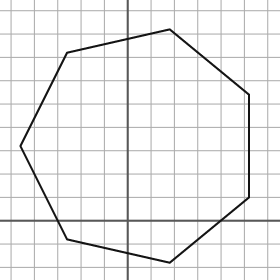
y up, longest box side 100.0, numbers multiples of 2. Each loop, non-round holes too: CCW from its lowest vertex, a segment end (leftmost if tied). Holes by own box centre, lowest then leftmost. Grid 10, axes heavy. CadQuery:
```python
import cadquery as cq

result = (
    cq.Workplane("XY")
    .moveTo(18.0, -18.0)
    .lineTo(52.0, 10.0)
    .lineTo(52.0, 54.0)
    .lineTo(18.0, 82.0)
    .lineTo(-26.0, 72.0)
    .lineTo(-46.0, 32.0)
    .lineTo(-26.0, -8.0)
    .close()
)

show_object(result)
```